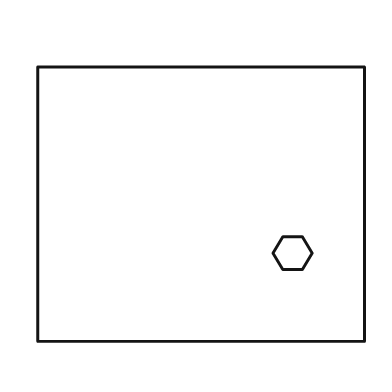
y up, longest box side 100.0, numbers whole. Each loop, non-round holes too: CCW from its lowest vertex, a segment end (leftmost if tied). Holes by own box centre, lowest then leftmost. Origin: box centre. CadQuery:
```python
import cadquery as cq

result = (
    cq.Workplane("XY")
    .moveTo(-50.0, -42.0)
    .lineTo(50.0, -42.0)
    .lineTo(50.0, 42.0)
    .lineTo(-50.0, 42.0)
    .close()
    .moveTo(25.0, -20.0)
    .lineTo(31.0, -20.0)
    .lineTo(34.0, -15.0)
    .lineTo(31.0, -10.0)
    .lineTo(25.0, -10.0)
    .lineTo(22.0, -15.0)
    .close()
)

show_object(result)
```